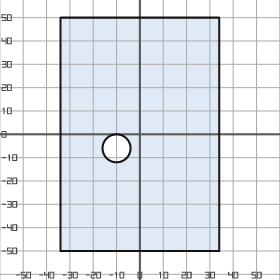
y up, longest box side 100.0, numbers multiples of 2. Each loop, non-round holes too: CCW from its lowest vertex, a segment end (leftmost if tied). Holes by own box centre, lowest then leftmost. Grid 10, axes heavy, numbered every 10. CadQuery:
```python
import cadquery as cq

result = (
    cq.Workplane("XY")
    .moveTo(-34.0, -50.0)
    .lineTo(34.0, -50.0)
    .lineTo(34.0, 50.0)
    .lineTo(-34.0, 50.0)
    .close()
    .moveTo(-10.0, -6.0)
    .circle(6.0)
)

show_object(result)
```